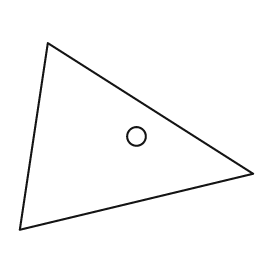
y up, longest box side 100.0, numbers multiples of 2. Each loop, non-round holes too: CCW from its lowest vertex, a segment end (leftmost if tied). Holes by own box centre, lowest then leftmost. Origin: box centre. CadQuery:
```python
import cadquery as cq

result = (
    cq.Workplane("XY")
    .moveTo(-50.0, -40.0)
    .lineTo(50.0, -16.0)
    .lineTo(-38.0, 40.0)
    .close()
    .moveTo(0.0, 0.0)
    .circle(4.0)
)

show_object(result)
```